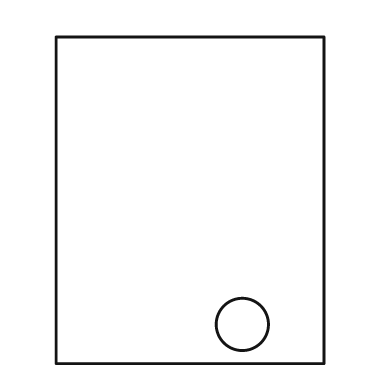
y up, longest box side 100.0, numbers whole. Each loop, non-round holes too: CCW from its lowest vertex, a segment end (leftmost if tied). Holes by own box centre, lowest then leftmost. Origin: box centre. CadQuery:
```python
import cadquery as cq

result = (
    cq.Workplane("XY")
    .moveTo(-41.0, -50.0)
    .lineTo(41.0, -50.0)
    .lineTo(41.0, 50.0)
    .lineTo(-41.0, 50.0)
    .close()
    .moveTo(16.0, -38.0)
    .circle(8.0)
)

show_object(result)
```